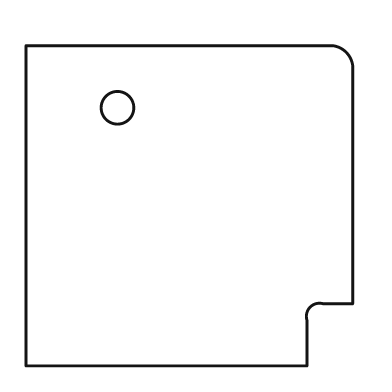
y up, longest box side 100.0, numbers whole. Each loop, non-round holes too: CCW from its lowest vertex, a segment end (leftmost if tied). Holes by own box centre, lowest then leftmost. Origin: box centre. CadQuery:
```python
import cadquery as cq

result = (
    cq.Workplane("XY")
    .moveTo(-50.0, -49.0)
    .lineTo(36.0, -49.0)
    .lineTo(36.0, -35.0)
    .threePointArc((37.0, -31.0), (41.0, -30.0))
    .lineTo(50.0, -30.0)
    .lineTo(50.0, 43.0)
    .threePointArc((48.0, 47.0), (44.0, 49.0))
    .lineTo(-50.0, 49.0)
    .close()
    .moveTo(-22.0, 30.0)
    .circle(5.0)
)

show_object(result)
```